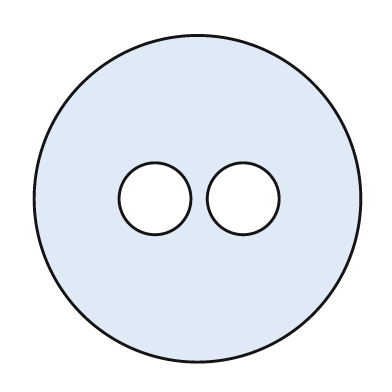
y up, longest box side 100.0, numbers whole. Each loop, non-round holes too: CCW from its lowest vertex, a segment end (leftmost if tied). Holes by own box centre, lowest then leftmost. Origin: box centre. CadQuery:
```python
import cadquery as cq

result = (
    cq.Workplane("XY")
    .moveTo(0.0, 0.0)
    .circle(50.0)
    .moveTo(-13.0, 0.0)
    .circle(11.0)
    .moveTo(14.0, 0.0)
    .circle(11.0)
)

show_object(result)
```